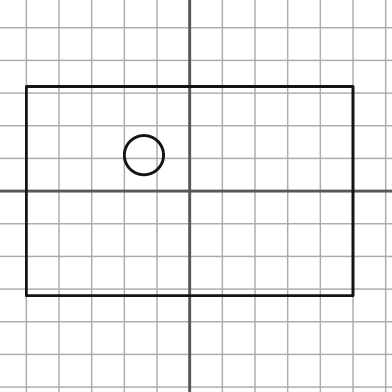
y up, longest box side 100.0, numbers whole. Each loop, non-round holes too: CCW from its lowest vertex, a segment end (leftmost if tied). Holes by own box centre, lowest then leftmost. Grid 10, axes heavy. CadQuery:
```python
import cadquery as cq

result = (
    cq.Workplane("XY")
    .moveTo(-50.0, -32.0)
    .lineTo(50.0, -32.0)
    .lineTo(50.0, 32.0)
    .lineTo(-50.0, 32.0)
    .close()
    .moveTo(-14.0, 11.0)
    .circle(6.0)
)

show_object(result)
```